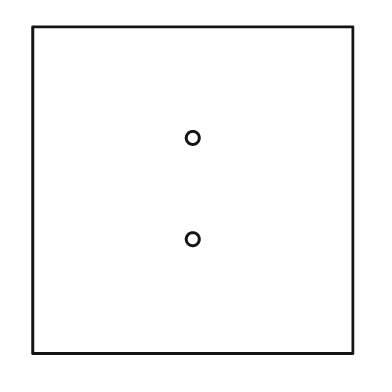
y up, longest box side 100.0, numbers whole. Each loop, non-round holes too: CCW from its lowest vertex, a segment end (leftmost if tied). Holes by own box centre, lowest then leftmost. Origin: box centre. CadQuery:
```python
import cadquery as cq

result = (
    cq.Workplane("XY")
    .moveTo(-49.0, -50.0)
    .lineTo(49.0, -50.0)
    .lineTo(49.0, 50.0)
    .lineTo(-49.0, 50.0)
    .close()
    .moveTo(0.0, -15.0)
    .circle(2.0)
    .moveTo(0.0, 16.0)
    .circle(2.0)
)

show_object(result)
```